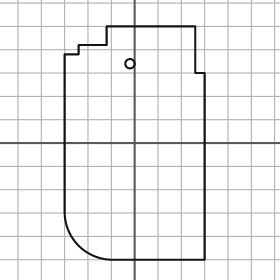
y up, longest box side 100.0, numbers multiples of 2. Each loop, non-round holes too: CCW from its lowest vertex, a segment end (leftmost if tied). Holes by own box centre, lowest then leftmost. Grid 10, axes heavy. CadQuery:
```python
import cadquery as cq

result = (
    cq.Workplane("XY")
    .moveTo(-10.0, -50.0)
    .lineTo(30.0, -50.0)
    .lineTo(30.0, 30.0)
    .lineTo(26.0, 30.0)
    .lineTo(26.0, 50.0)
    .lineTo(-12.0, 50.0)
    .lineTo(-12.0, 42.0)
    .lineTo(-24.0, 42.0)
    .lineTo(-24.0, 38.0)
    .lineTo(-30.0, 38.0)
    .lineTo(-30.0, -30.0)
    .threePointArc((-24.0, -44.0), (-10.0, -50.0))
    .close()
    .moveTo(-2.0, 34.0)
    .circle(2.0)
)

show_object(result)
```